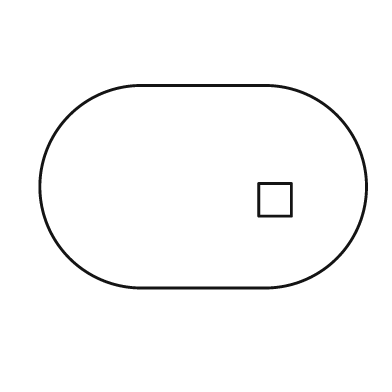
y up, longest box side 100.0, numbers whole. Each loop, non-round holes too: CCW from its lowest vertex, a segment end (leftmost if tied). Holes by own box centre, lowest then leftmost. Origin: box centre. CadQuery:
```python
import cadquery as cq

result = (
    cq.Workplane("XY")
    .moveTo(-19.0, -31.0)
    .lineTo(19.0, -31.0)
    .threePointArc((50.0, 0.0), (19.0, 31.0))
    .lineTo(-19.0, 31.0)
    .threePointArc((-50.0, 0.0), (-19.0, -31.0))
    .close()
    .moveTo(17.0, -9.0)
    .lineTo(27.0, -9.0)
    .lineTo(27.0, 1.0)
    .lineTo(17.0, 1.0)
    .close()
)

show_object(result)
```